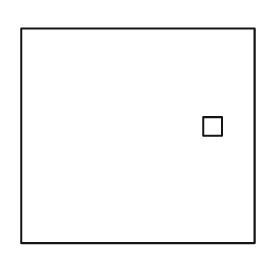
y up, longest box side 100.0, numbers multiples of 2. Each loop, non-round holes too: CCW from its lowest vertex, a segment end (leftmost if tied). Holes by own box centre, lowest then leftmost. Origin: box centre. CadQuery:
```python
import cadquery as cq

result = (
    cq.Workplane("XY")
    .moveTo(-50.0, -46.0)
    .lineTo(50.0, -46.0)
    .lineTo(50.0, 46.0)
    .lineTo(-50.0, 46.0)
    .close()
    .moveTo(28.0, 0.0)
    .lineTo(36.0, 0.0)
    .lineTo(36.0, 8.0)
    .lineTo(28.0, 8.0)
    .close()
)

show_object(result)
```